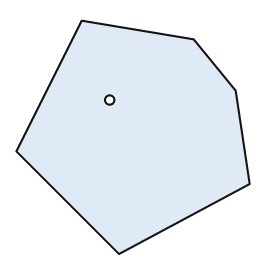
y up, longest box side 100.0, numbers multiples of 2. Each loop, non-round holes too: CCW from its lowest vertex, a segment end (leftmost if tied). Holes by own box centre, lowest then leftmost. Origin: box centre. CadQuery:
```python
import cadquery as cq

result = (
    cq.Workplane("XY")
    .moveTo(-6.0, -50.0)
    .lineTo(50.0, -20.0)
    .lineTo(44.0, 20.0)
    .lineTo(26.0, 42.0)
    .lineTo(-22.0, 50.0)
    .lineTo(-50.0, -6.0)
    .close()
    .moveTo(-10.0, 16.0)
    .circle(2.0)
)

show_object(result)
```